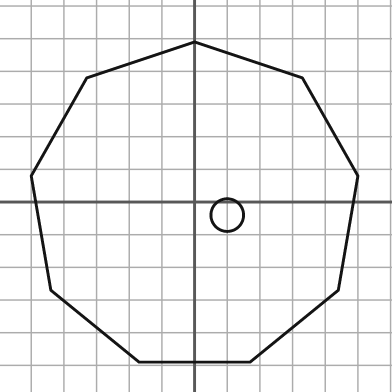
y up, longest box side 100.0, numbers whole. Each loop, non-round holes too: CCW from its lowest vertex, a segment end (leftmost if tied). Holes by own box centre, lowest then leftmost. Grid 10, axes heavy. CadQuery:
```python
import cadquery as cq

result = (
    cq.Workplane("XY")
    .moveTo(-17.0, -49.0)
    .lineTo(17.0, -49.0)
    .lineTo(44.0, -27.0)
    .lineTo(50.0, 8.0)
    .lineTo(33.0, 38.0)
    .lineTo(0.0, 49.0)
    .lineTo(-33.0, 38.0)
    .lineTo(-50.0, 8.0)
    .lineTo(-44.0, -27.0)
    .close()
    .moveTo(10.0, -4.0)
    .circle(5.0)
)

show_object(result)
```